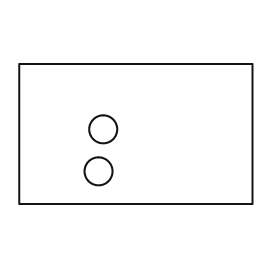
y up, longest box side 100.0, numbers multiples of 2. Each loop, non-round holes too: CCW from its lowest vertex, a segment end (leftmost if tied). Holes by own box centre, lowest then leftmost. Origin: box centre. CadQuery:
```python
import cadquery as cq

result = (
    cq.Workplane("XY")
    .moveTo(-50.0, -30.0)
    .lineTo(50.0, -30.0)
    .lineTo(50.0, 30.0)
    .lineTo(-50.0, 30.0)
    .close()
    .moveTo(-16.0, -16.0)
    .circle(6.0)
    .moveTo(-14.0, 2.0)
    .circle(6.0)
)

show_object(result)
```